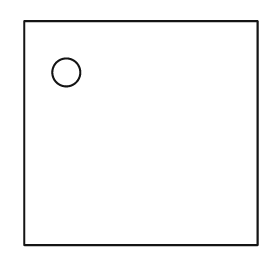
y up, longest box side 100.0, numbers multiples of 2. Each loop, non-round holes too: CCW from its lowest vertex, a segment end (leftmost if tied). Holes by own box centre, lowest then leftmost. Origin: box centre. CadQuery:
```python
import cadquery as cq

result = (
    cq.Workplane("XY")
    .moveTo(-50.0, -48.0)
    .lineTo(50.0, -48.0)
    .lineTo(50.0, 48.0)
    .lineTo(-50.0, 48.0)
    .close()
    .moveTo(-32.0, 26.0)
    .circle(6.0)
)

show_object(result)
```